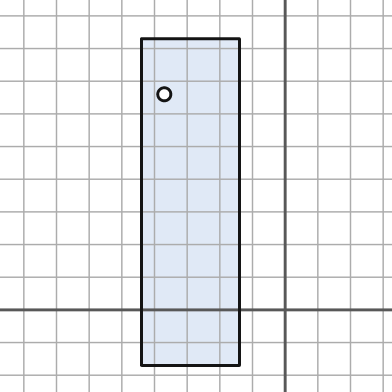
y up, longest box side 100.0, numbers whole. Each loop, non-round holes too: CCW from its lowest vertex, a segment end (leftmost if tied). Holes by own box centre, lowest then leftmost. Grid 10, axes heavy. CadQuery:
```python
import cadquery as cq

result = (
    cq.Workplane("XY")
    .moveTo(-44.0, -17.0)
    .lineTo(-14.0, -17.0)
    .lineTo(-14.0, 83.0)
    .lineTo(-44.0, 83.0)
    .close()
    .moveTo(-37.0, 66.0)
    .circle(2.0)
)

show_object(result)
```